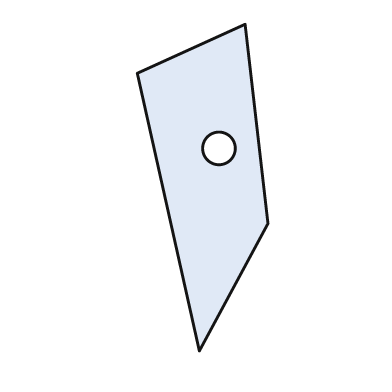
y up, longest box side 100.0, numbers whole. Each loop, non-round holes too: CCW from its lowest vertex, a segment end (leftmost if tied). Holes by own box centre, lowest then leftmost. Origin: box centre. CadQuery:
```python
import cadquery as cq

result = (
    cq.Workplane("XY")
    .moveTo(-1.0, -50.0)
    .lineTo(20.0, -11.0)
    .lineTo(13.0, 50.0)
    .lineTo(-20.0, 35.0)
    .close()
    .moveTo(5.0, 12.0)
    .circle(5.0)
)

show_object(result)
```